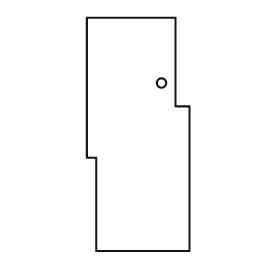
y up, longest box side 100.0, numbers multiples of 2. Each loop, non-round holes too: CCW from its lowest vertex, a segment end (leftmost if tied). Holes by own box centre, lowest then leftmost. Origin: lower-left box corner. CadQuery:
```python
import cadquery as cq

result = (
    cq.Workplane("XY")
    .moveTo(4.0, 0.0)
    .lineTo(44.0, 0.0)
    .lineTo(44.0, 62.0)
    .lineTo(38.0, 62.0)
    .lineTo(38.0, 100.0)
    .lineTo(0.0, 100.0)
    .lineTo(0.0, 40.0)
    .lineTo(4.0, 40.0)
    .close()
    .moveTo(32.0, 72.0)
    .circle(2.0)
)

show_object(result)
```